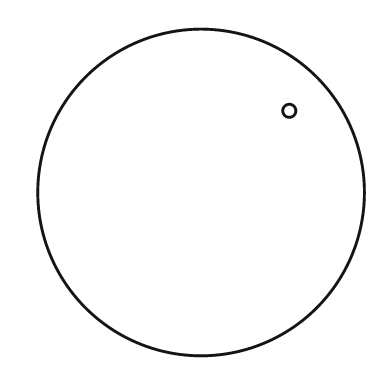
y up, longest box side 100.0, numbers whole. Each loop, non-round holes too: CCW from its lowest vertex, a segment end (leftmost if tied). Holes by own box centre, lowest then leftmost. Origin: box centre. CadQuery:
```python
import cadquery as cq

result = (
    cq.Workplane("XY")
    .moveTo(0.0, 0.0)
    .circle(50.0)
    .moveTo(27.0, 25.0)
    .circle(2.0)
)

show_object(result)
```